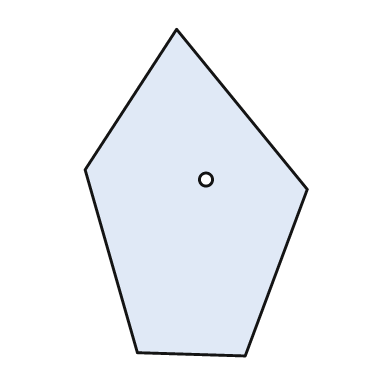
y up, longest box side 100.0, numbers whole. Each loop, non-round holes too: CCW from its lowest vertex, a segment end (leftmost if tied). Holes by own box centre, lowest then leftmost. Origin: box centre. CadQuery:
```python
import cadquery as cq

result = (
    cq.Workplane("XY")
    .moveTo(15.0, -50.0)
    .lineTo(34.0, 1.0)
    .lineTo(-6.0, 50.0)
    .lineTo(-34.0, 7.0)
    .lineTo(-18.0, -49.0)
    .close()
    .moveTo(3.0, 4.0)
    .circle(2.0)
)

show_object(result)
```